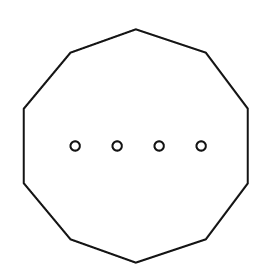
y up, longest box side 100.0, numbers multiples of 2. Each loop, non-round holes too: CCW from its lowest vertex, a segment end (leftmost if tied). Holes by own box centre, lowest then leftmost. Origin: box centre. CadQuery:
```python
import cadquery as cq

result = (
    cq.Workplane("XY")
    .moveTo(0.0, -50.0)
    .lineTo(30.0, -40.0)
    .lineTo(48.0, -16.0)
    .lineTo(48.0, 16.0)
    .lineTo(30.0, 40.0)
    .lineTo(0.0, 50.0)
    .lineTo(-28.0, 40.0)
    .lineTo(-48.0, 16.0)
    .lineTo(-48.0, -16.0)
    .lineTo(-28.0, -40.0)
    .close()
    .moveTo(-26.0, 0.0)
    .circle(2.0)
    .moveTo(-8.0, 0.0)
    .circle(2.0)
    .moveTo(10.0, 0.0)
    .circle(2.0)
    .moveTo(28.0, 0.0)
    .circle(2.0)
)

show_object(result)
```